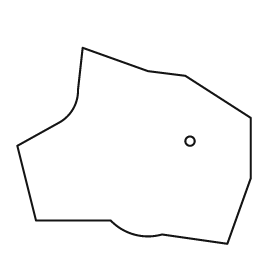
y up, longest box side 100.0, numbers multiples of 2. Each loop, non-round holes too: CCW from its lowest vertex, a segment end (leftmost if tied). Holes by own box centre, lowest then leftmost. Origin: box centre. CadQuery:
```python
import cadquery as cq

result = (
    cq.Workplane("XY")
    .moveTo(40.0, -42.0)
    .lineTo(50.0, -14.0)
    .lineTo(50.0, 12.0)
    .lineTo(22.0, 30.0)
    .lineTo(6.0, 32.0)
    .lineTo(-22.0, 42.0)
    .lineTo(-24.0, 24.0)
    .threePointArc((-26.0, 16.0), (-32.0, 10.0))
    .lineTo(-50.0, 0.0)
    .lineTo(-42.0, -32.0)
    .lineTo(-10.0, -32.0)
    .threePointArc((0.0, -38.0), (12.0, -38.0))
    .close()
    .moveTo(24.0, 2.0)
    .circle(2.0)
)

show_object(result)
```